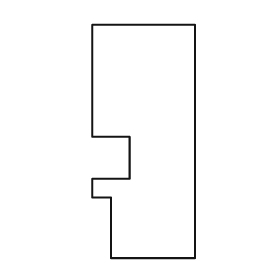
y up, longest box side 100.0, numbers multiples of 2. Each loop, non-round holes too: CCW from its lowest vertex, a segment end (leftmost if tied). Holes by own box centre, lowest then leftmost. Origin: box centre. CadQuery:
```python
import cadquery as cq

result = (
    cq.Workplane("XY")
    .moveTo(-14.0, -50.0)
    .lineTo(22.0, -50.0)
    .lineTo(22.0, 50.0)
    .lineTo(-22.0, 50.0)
    .lineTo(-22.0, 2.0)
    .lineTo(-6.0, 2.0)
    .lineTo(-6.0, -16.0)
    .lineTo(-22.0, -16.0)
    .lineTo(-22.0, -24.0)
    .lineTo(-14.0, -24.0)
    .close()
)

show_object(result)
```